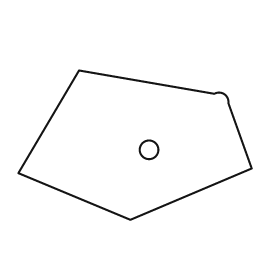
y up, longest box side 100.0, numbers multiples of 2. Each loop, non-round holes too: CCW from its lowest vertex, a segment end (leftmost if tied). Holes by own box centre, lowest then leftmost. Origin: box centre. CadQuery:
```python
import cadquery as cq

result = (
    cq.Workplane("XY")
    .moveTo(-2.0, -32.0)
    .lineTo(50.0, -10.0)
    .lineTo(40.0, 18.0)
    .threePointArc((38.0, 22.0), (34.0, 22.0))
    .lineTo(-24.0, 32.0)
    .lineTo(-50.0, -12.0)
    .close()
    .moveTo(6.0, -2.0)
    .circle(4.0)
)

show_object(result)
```